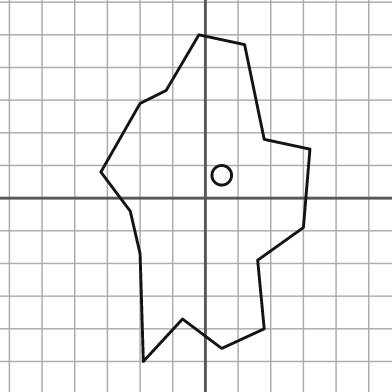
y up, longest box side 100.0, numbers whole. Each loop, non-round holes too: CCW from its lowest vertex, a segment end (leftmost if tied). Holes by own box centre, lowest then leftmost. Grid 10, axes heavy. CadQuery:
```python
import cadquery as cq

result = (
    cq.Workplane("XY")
    .moveTo(-19.0, -50.0)
    .lineTo(-7.0, -37.0)
    .lineTo(5.0, -46.0)
    .lineTo(18.0, -40.0)
    .lineTo(16.0, -19.0)
    .lineTo(30.0, -9.0)
    .lineTo(32.0, 15.0)
    .lineTo(18.0, 18.0)
    .lineTo(12.0, 47.0)
    .lineTo(-2.0, 50.0)
    .lineTo(-12.0, 33.0)
    .lineTo(-20.0, 29.0)
    .lineTo(-32.0, 8.0)
    .lineTo(-23.0, -4.0)
    .lineTo(-20.0, -17.0)
    .close()
    .moveTo(5.0, 7.0)
    .circle(3.0)
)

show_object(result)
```